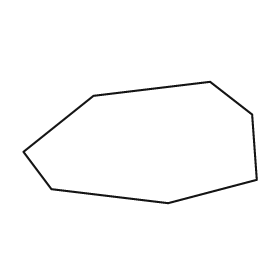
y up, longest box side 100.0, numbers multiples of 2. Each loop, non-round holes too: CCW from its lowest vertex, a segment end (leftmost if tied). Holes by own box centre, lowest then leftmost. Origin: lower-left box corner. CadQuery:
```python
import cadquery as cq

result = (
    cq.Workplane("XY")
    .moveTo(62.0, 0.0)
    .lineTo(100.0, 10.0)
    .lineTo(98.0, 38.0)
    .lineTo(80.0, 52.0)
    .lineTo(30.0, 46.0)
    .lineTo(0.0, 22.0)
    .lineTo(12.0, 6.0)
    .close()
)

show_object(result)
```